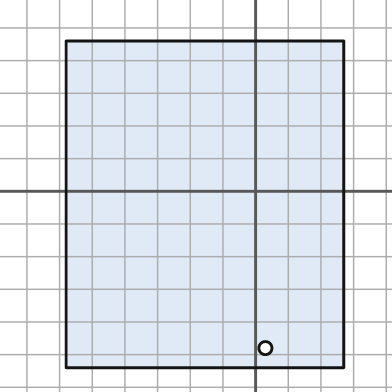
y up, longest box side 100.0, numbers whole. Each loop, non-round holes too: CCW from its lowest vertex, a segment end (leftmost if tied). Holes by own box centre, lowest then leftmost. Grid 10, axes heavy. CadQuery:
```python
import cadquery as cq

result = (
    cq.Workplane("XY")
    .moveTo(-58.0, -54.0)
    .lineTo(27.0, -54.0)
    .lineTo(27.0, 46.0)
    .lineTo(-58.0, 46.0)
    .close()
    .moveTo(3.0, -48.0)
    .circle(2.0)
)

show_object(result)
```